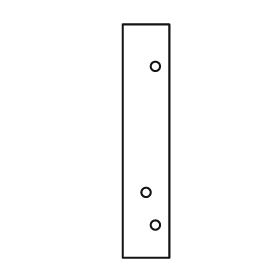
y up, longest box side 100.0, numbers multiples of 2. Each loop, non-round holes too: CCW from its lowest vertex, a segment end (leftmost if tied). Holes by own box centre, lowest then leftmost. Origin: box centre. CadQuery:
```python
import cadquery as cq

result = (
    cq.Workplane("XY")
    .moveTo(-10.0, -50.0)
    .lineTo(10.0, -50.0)
    .lineTo(10.0, 50.0)
    .lineTo(-10.0, 50.0)
    .close()
    .moveTo(4.0, -36.0)
    .circle(2.0)
    .moveTo(0.0, -22.0)
    .circle(2.0)
    .moveTo(4.0, 32.0)
    .circle(2.0)
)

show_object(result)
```